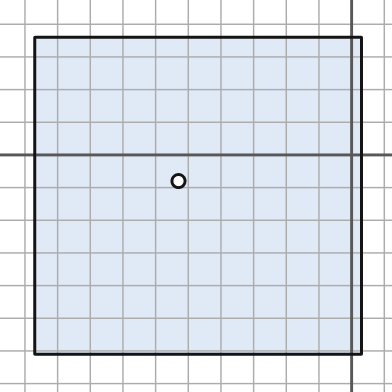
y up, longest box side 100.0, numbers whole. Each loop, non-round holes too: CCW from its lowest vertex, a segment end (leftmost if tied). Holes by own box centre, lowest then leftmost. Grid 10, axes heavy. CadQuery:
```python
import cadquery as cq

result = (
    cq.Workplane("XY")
    .moveTo(-97.0, -61.0)
    .lineTo(3.0, -61.0)
    .lineTo(3.0, 36.0)
    .lineTo(-97.0, 36.0)
    .close()
    .moveTo(-53.0, -8.0)
    .circle(2.0)
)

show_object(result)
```